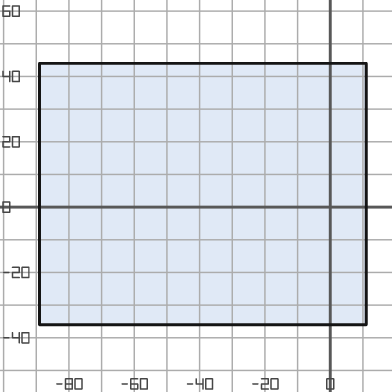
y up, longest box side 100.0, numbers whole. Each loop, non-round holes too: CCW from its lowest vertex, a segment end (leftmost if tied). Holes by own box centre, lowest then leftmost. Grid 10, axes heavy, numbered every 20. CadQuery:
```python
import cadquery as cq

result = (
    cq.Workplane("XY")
    .moveTo(-89.0, -36.0)
    .lineTo(11.0, -36.0)
    .lineTo(11.0, 44.0)
    .lineTo(-89.0, 44.0)
    .close()
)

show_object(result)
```